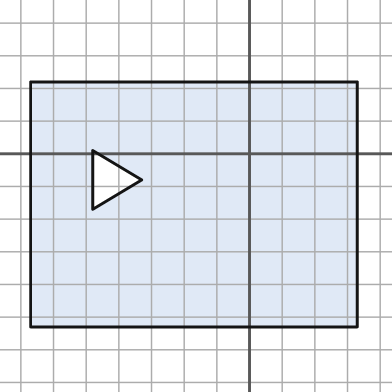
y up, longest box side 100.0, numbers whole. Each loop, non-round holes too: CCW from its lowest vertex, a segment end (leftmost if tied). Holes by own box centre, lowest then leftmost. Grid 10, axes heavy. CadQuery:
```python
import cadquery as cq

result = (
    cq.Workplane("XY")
    .moveTo(-67.0, -53.0)
    .lineTo(33.0, -53.0)
    .lineTo(33.0, 22.0)
    .lineTo(-67.0, 22.0)
    .close()
    .moveTo(-48.0, -17.0)
    .lineTo(-33.0, -8.0)
    .lineTo(-48.0, 1.0)
    .close()
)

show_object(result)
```